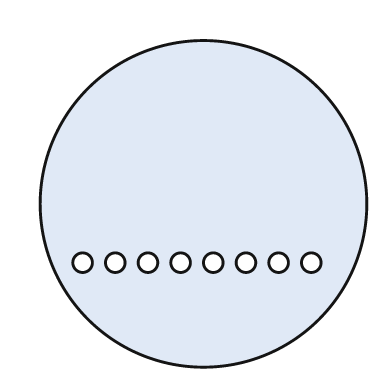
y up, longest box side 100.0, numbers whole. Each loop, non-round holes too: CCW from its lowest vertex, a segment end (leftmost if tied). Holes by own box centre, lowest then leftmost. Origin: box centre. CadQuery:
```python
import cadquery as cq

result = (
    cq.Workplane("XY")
    .moveTo(0.0, 0.0)
    .circle(50.0)
    .moveTo(-37.0, -18.0)
    .circle(3.0)
    .moveTo(-27.0, -18.0)
    .circle(3.0)
    .moveTo(-17.0, -18.0)
    .circle(3.0)
    .moveTo(-7.0, -18.0)
    .circle(3.0)
    .moveTo(3.0, -18.0)
    .circle(3.0)
    .moveTo(13.0, -18.0)
    .circle(3.0)
    .moveTo(23.0, -18.0)
    .circle(3.0)
    .moveTo(33.0, -18.0)
    .circle(3.0)
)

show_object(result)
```